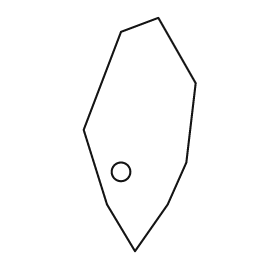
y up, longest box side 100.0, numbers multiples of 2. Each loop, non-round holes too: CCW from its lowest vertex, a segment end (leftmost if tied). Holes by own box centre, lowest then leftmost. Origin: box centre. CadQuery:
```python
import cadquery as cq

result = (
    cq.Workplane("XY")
    .moveTo(-2.0, -50.0)
    .lineTo(12.0, -30.0)
    .lineTo(20.0, -12.0)
    .lineTo(24.0, 22.0)
    .lineTo(8.0, 50.0)
    .lineTo(-8.0, 44.0)
    .lineTo(-24.0, 2.0)
    .lineTo(-14.0, -30.0)
    .close()
    .moveTo(-8.0, -16.0)
    .circle(4.0)
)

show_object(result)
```